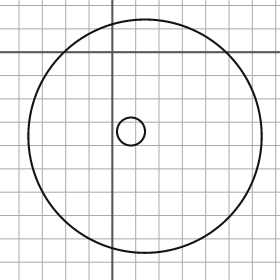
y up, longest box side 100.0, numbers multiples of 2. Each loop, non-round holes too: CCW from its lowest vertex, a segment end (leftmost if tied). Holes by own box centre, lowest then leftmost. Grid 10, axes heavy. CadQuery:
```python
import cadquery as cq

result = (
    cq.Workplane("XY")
    .moveTo(14.0, -36.0)
    .circle(50.0)
    .moveTo(8.0, -34.0)
    .circle(6.0)
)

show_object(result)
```